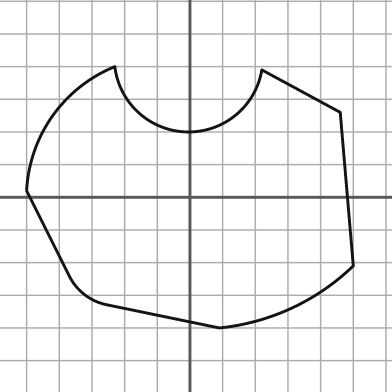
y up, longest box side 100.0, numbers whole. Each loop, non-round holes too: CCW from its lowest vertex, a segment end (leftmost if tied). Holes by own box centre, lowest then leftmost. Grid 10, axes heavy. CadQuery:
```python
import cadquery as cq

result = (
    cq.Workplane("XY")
    .moveTo(9.0, -40.0)
    .threePointArc((31.0, -34.0), (50.0, -21.0))
    .lineTo(46.0, 26.0)
    .lineTo(22.0, 39.0)
    .threePointArc((-1.0, 20.0), (-23.0, 40.0))
    .threePointArc((-42.0, 25.0), (-50.0, 2.0))
    .lineTo(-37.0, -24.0)
    .threePointArc((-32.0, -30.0), (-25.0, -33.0))
    .close()
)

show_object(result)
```